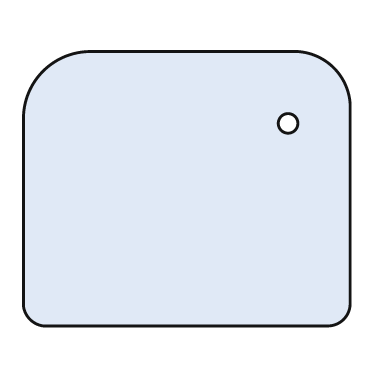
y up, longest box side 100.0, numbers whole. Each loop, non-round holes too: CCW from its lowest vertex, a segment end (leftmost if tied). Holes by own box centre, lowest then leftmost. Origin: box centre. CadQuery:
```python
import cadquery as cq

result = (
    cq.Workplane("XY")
    .moveTo(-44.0, -42.0)
    .lineTo(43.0, -42.0)
    .threePointArc((48.0, -40.0), (50.0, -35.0))
    .lineTo(50.0, 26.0)
    .threePointArc((45.0, 37.0), (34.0, 42.0))
    .lineTo(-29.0, 42.0)
    .threePointArc((-44.0, 36.0), (-50.0, 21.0))
    .lineTo(-50.0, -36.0)
    .threePointArc((-48.0, -40.0), (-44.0, -42.0))
    .close()
    .moveTo(31.0, 20.0)
    .circle(3.0)
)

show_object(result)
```